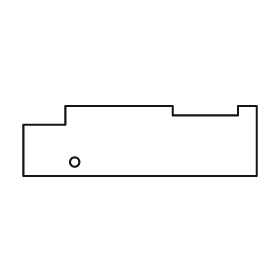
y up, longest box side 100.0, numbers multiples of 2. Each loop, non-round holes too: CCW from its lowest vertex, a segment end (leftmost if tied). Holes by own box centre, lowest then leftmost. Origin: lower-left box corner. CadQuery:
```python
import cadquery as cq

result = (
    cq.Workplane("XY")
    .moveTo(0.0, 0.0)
    .lineTo(100.0, 0.0)
    .lineTo(100.0, 30.0)
    .lineTo(92.0, 30.0)
    .lineTo(92.0, 26.0)
    .lineTo(64.0, 26.0)
    .lineTo(64.0, 30.0)
    .lineTo(18.0, 30.0)
    .lineTo(18.0, 22.0)
    .lineTo(0.0, 22.0)
    .close()
    .moveTo(22.0, 6.0)
    .circle(2.0)
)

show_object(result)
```